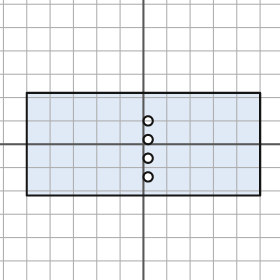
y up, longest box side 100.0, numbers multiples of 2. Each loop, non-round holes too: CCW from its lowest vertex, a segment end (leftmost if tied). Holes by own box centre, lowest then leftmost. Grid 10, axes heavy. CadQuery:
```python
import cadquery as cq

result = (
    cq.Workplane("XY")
    .moveTo(-50.0, -22.0)
    .lineTo(50.0, -22.0)
    .lineTo(50.0, 22.0)
    .lineTo(-50.0, 22.0)
    .close()
    .moveTo(2.0, -14.0)
    .circle(2.0)
    .moveTo(2.0, -6.0)
    .circle(2.0)
    .moveTo(2.0, 2.0)
    .circle(2.0)
    .moveTo(2.0, 10.0)
    .circle(2.0)
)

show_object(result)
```